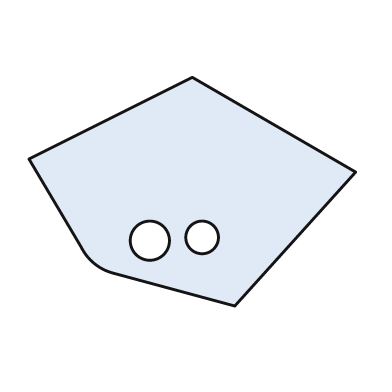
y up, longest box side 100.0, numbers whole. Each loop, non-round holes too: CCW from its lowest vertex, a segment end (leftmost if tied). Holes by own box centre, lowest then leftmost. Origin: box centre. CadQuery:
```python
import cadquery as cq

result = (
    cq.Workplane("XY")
    .moveTo(13.0, -35.0)
    .lineTo(50.0, 6.0)
    .lineTo(0.0, 35.0)
    .lineTo(-50.0, 10.0)
    .lineTo(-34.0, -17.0)
    .threePointArc((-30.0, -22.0), (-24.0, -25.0))
    .close()
    .moveTo(-13.0, -15.0)
    .circle(6.0)
    .moveTo(3.0, -14.0)
    .circle(5.0)
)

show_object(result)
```